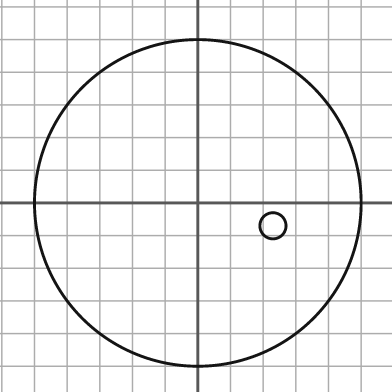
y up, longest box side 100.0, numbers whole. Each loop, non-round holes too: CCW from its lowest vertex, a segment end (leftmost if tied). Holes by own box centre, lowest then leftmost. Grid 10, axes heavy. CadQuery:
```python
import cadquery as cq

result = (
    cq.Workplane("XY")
    .moveTo(0.0, 0.0)
    .circle(50.0)
    .moveTo(23.0, -7.0)
    .circle(4.0)
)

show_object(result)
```